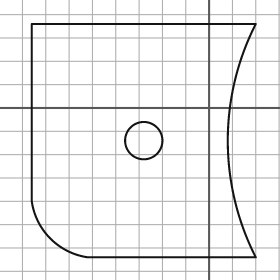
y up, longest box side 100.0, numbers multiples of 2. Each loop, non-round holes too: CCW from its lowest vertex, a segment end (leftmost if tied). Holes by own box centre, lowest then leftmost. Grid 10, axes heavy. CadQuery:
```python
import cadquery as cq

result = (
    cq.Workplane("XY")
    .moveTo(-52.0, -64.0)
    .lineTo(20.0, -64.0)
    .threePointArc((8.0, -14.0), (20.0, 36.0))
    .lineTo(-76.0, 36.0)
    .lineTo(-76.0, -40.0)
    .threePointArc((-68.0, -56.0), (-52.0, -64.0))
    .close()
    .moveTo(-28.0, -14.0)
    .circle(8.0)
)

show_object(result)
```